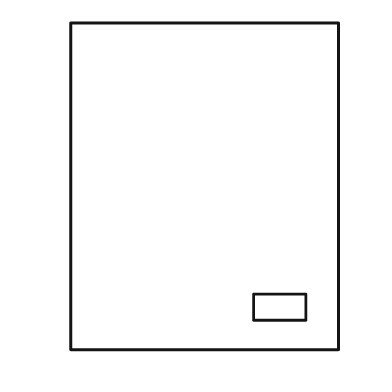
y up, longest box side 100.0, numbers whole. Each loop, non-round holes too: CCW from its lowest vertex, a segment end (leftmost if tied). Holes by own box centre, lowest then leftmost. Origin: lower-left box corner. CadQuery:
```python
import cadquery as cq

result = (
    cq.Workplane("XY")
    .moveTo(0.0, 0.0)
    .lineTo(82.0, 0.0)
    .lineTo(82.0, 100.0)
    .lineTo(0.0, 100.0)
    .close()
    .moveTo(56.0, 9.0)
    .lineTo(72.0, 9.0)
    .lineTo(72.0, 17.0)
    .lineTo(56.0, 17.0)
    .close()
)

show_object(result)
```